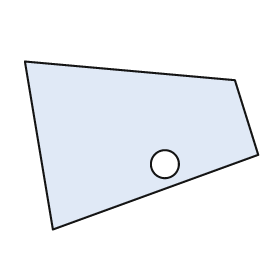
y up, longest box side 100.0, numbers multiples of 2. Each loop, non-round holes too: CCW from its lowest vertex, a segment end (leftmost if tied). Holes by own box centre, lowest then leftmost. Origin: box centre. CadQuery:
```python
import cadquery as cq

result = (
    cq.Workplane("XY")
    .moveTo(-38.0, -36.0)
    .lineTo(50.0, -4.0)
    .lineTo(40.0, 28.0)
    .lineTo(-50.0, 36.0)
    .close()
    .moveTo(10.0, -8.0)
    .circle(6.0)
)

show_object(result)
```